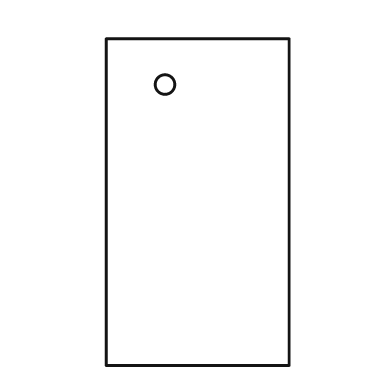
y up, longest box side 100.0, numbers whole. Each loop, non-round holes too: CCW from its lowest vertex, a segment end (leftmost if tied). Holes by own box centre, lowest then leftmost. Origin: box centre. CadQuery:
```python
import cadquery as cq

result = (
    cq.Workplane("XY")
    .moveTo(-28.0, -50.0)
    .lineTo(28.0, -50.0)
    .lineTo(28.0, 50.0)
    .lineTo(-28.0, 50.0)
    .close()
    .moveTo(-10.0, 36.0)
    .circle(3.0)
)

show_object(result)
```